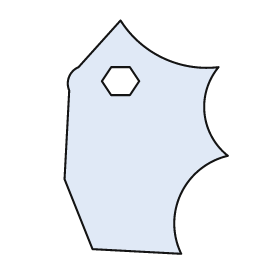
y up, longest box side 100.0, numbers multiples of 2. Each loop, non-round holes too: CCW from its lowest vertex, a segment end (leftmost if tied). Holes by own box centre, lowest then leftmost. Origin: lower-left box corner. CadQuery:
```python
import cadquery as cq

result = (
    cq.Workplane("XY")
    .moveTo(50.0, 0.0)
    .threePointArc((50.0, 26.0), (70.0, 42.0))
    .threePointArc((60.0, 60.0), (66.0, 80.0))
    .threePointArc((42.0, 84.0), (24.0, 100.0))
    .lineTo(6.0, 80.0)
    .threePointArc((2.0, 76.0), (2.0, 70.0))
    .lineTo(0.0, 32.0)
    .lineTo(12.0, 2.0)
    .close()
    .moveTo(20.0, 68.0)
    .lineTo(28.0, 68.0)
    .lineTo(32.0, 74.0)
    .lineTo(28.0, 80.0)
    .lineTo(20.0, 80.0)
    .lineTo(16.0, 74.0)
    .close()
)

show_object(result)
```